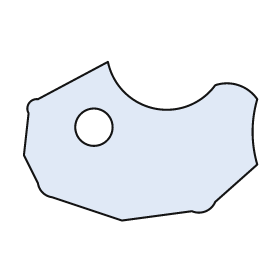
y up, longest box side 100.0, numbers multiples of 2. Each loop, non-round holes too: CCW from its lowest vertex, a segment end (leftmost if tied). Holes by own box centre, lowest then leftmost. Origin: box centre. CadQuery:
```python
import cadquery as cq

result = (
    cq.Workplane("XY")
    .moveTo(-8.0, -34.0)
    .lineTo(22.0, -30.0)
    .threePointArc((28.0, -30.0), (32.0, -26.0))
    .lineTo(50.0, -10.0)
    .threePointArc((48.0, 4.0), (50.0, 18.0))
    .threePointArc((42.0, 24.0), (32.0, 24.0))
    .threePointArc((6.0, 14.0), (-14.0, 34.0))
    .lineTo(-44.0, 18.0)
    .threePointArc((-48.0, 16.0), (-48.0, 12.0))
    .lineTo(-50.0, -6.0)
    .lineTo(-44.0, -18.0)
    .threePointArc((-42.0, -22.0), (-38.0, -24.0))
    .close()
    .moveTo(-20.0, 6.0)
    .circle(8.0)
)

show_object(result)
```